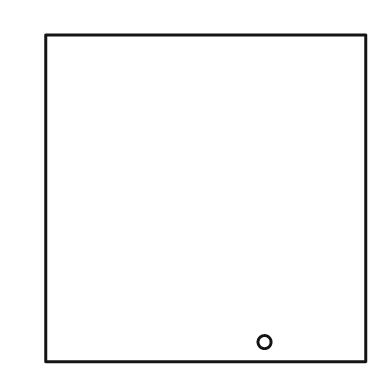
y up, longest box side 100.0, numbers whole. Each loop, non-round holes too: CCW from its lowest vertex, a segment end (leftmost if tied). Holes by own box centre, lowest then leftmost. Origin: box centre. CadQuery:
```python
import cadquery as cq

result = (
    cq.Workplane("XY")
    .moveTo(-49.0, -50.0)
    .lineTo(49.0, -50.0)
    .lineTo(49.0, 50.0)
    .lineTo(-49.0, 50.0)
    .close()
    .moveTo(18.0, -44.0)
    .circle(2.0)
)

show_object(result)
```